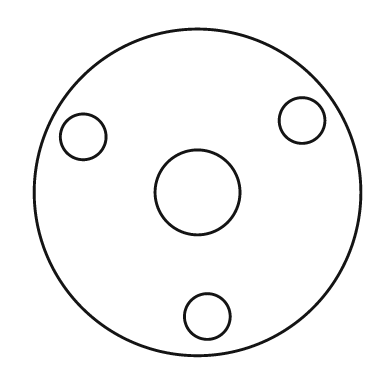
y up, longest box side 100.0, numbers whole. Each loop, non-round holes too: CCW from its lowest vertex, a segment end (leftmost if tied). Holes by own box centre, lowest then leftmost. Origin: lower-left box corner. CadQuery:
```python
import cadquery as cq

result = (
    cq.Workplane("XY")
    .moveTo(50.0, 50.0)
    .circle(50.0)
    .moveTo(53.0, 12.0)
    .circle(7.0)
    .moveTo(50.0, 50.0)
    .circle(13.0)
    .moveTo(15.0, 67.0)
    .circle(7.0)
    .moveTo(82.0, 72.0)
    .circle(7.0)
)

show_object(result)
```